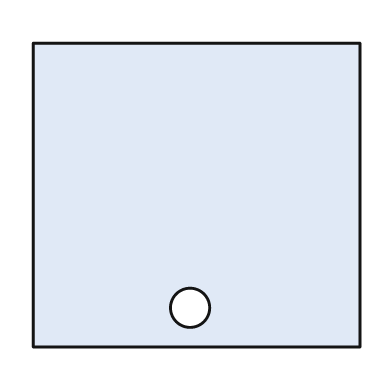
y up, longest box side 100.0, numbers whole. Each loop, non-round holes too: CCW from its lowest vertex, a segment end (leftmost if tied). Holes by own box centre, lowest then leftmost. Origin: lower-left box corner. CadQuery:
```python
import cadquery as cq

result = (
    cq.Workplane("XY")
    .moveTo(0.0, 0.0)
    .lineTo(100.0, 0.0)
    .lineTo(100.0, 93.0)
    .lineTo(0.0, 93.0)
    .close()
    .moveTo(48.0, 12.0)
    .circle(6.0)
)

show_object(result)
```